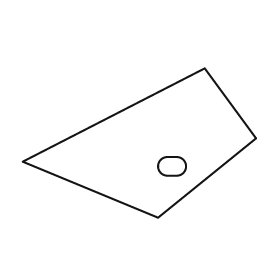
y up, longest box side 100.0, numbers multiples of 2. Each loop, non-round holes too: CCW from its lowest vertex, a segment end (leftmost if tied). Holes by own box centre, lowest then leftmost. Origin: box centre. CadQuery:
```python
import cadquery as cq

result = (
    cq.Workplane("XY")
    .moveTo(8.0, -32.0)
    .lineTo(50.0, 2.0)
    .lineTo(28.0, 32.0)
    .lineTo(-50.0, -8.0)
    .close()
    .moveTo(12.0, -14.0)
    .lineTo(16.0, -14.0)
    .threePointArc((20.0, -10.0), (16.0, -6.0))
    .lineTo(12.0, -6.0)
    .threePointArc((8.0, -10.0), (12.0, -14.0))
    .close()
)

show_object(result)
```